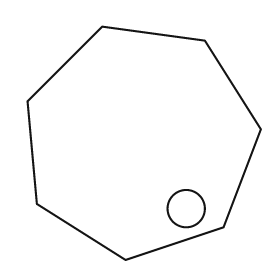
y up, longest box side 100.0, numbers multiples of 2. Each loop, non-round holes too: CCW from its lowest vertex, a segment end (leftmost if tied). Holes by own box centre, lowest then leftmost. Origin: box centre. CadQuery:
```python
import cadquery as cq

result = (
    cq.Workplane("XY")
    .moveTo(-8.0, -50.0)
    .lineTo(34.0, -36.0)
    .lineTo(50.0, 6.0)
    .lineTo(26.0, 44.0)
    .lineTo(-18.0, 50.0)
    .lineTo(-50.0, 18.0)
    .lineTo(-46.0, -26.0)
    .close()
    .moveTo(18.0, -28.0)
    .circle(8.0)
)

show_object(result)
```